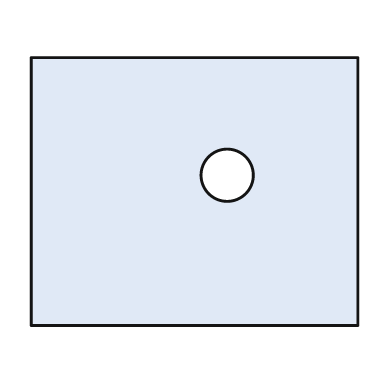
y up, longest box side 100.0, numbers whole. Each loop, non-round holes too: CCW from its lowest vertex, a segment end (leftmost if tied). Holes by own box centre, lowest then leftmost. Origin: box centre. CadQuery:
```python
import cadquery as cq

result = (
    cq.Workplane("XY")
    .moveTo(-50.0, -41.0)
    .lineTo(50.0, -41.0)
    .lineTo(50.0, 41.0)
    .lineTo(-50.0, 41.0)
    .close()
    .moveTo(10.0, 5.0)
    .circle(8.0)
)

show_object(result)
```